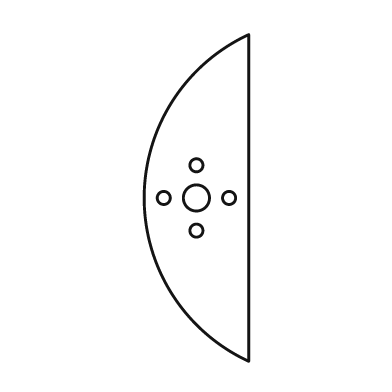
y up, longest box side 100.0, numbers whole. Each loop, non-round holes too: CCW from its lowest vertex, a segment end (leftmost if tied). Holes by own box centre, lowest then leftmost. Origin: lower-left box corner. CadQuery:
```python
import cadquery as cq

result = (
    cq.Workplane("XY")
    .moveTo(32.0, 0.0)
    .lineTo(32.0, 100.0)
    .threePointArc((0.0, 50.0), (32.0, 0.0))
    .close()
    .moveTo(16.0, 40.0)
    .circle(2.0)
    .moveTo(6.0, 50.0)
    .circle(2.0)
    .moveTo(16.0, 50.0)
    .circle(4.0)
    .moveTo(26.0, 50.0)
    .circle(2.0)
    .moveTo(16.0, 60.0)
    .circle(2.0)
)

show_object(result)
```